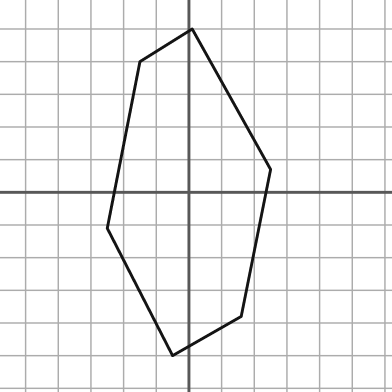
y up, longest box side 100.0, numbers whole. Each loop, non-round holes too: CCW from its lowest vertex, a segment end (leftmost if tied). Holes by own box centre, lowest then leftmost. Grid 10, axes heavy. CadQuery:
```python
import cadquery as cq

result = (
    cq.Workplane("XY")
    .moveTo(-5.0, -50.0)
    .lineTo(16.0, -38.0)
    .lineTo(25.0, 7.0)
    .lineTo(1.0, 50.0)
    .lineTo(-15.0, 40.0)
    .lineTo(-25.0, -11.0)
    .close()
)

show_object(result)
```